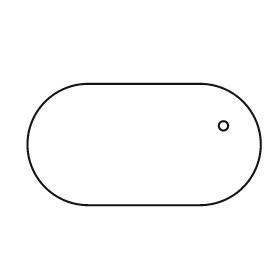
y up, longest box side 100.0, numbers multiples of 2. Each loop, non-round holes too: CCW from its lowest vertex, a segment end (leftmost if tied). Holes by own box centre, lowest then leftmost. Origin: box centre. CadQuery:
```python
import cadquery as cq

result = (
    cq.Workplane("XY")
    .moveTo(-24.0, -26.0)
    .lineTo(24.0, -26.0)
    .threePointArc((50.0, 0.0), (24.0, 26.0))
    .lineTo(-24.0, 26.0)
    .threePointArc((-50.0, 0.0), (-24.0, -26.0))
    .close()
    .moveTo(34.0, 8.0)
    .circle(2.0)
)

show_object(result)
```